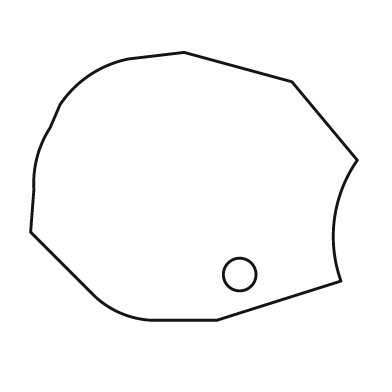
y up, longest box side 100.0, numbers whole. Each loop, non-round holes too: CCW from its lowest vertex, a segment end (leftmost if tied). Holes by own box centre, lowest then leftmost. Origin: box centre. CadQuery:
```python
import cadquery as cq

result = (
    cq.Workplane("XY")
    .moveTo(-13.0, -41.0)
    .lineTo(7.0, -41.0)
    .lineTo(45.0, -29.0)
    .threePointArc((43.0, -10.0), (50.0, 8.0))
    .lineTo(30.0, 32.0)
    .lineTo(-3.0, 41.0)
    .lineTo(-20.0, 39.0)
    .threePointArc((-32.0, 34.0), (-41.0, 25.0))
    .lineTo(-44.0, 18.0)
    .threePointArc((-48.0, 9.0), (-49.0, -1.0))
    .lineTo(-50.0, -14.0)
    .lineTo(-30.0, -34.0)
    .threePointArc((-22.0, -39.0), (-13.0, -41.0))
    .close()
    .moveTo(14.0, -27.0)
    .circle(5.0)
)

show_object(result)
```